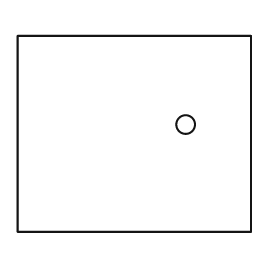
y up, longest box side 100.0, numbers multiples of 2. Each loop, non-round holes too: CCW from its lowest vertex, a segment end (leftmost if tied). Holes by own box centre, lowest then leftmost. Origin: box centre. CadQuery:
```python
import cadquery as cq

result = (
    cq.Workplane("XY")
    .moveTo(-50.0, -42.0)
    .lineTo(50.0, -42.0)
    .lineTo(50.0, 42.0)
    .lineTo(-50.0, 42.0)
    .close()
    .moveTo(22.0, 4.0)
    .circle(4.0)
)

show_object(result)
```